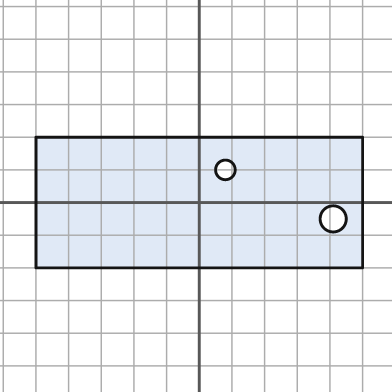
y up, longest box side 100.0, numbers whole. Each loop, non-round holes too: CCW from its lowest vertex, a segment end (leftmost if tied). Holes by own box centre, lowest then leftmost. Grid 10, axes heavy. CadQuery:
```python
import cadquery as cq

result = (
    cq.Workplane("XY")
    .moveTo(-50.0, -20.0)
    .lineTo(50.0, -20.0)
    .lineTo(50.0, 20.0)
    .lineTo(-50.0, 20.0)
    .close()
    .moveTo(41.0, -5.0)
    .circle(4.0)
    .moveTo(8.0, 10.0)
    .circle(3.0)
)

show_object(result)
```